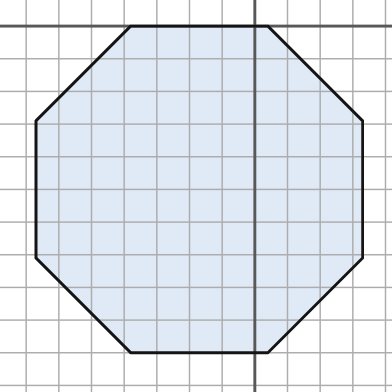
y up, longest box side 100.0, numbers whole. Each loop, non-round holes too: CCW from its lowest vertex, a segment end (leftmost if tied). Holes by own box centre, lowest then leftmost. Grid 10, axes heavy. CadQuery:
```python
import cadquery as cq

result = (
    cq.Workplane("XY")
    .moveTo(-38.0, -100.0)
    .lineTo(4.0, -100.0)
    .lineTo(33.0, -71.0)
    .lineTo(33.0, -29.0)
    .lineTo(4.0, 0.0)
    .lineTo(-38.0, 0.0)
    .lineTo(-67.0, -29.0)
    .lineTo(-67.0, -71.0)
    .close()
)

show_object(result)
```